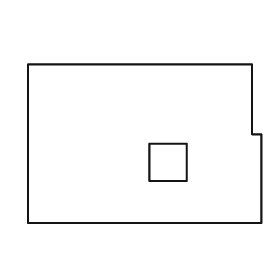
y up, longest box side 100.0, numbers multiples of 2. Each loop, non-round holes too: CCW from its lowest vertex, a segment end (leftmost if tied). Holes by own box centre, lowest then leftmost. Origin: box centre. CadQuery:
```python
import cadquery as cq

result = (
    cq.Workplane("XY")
    .moveTo(-50.0, -34.0)
    .lineTo(50.0, -34.0)
    .lineTo(50.0, 4.0)
    .lineTo(46.0, 4.0)
    .lineTo(46.0, 34.0)
    .lineTo(-50.0, 34.0)
    .close()
    .moveTo(2.0, -16.0)
    .lineTo(18.0, -16.0)
    .lineTo(18.0, 0.0)
    .lineTo(2.0, 0.0)
    .close()
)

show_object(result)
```